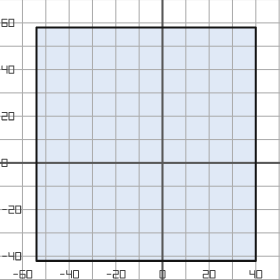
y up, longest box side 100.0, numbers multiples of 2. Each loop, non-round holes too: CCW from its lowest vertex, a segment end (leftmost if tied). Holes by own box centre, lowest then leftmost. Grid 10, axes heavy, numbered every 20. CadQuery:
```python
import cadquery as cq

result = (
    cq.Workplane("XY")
    .moveTo(-54.0, -42.0)
    .lineTo(40.0, -42.0)
    .lineTo(40.0, 58.0)
    .lineTo(-54.0, 58.0)
    .close()
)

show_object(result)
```